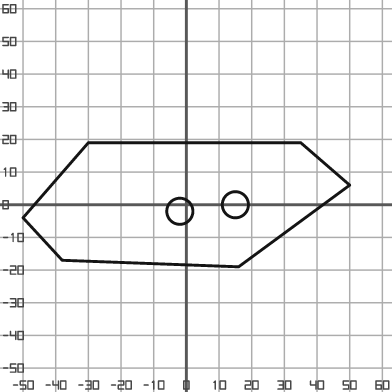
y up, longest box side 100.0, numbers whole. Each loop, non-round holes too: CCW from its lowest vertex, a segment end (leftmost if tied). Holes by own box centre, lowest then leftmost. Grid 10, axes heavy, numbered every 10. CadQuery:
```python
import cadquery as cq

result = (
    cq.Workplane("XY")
    .moveTo(16.0, -19.0)
    .lineTo(50.0, 6.0)
    .lineTo(35.0, 19.0)
    .lineTo(-30.0, 19.0)
    .lineTo(-50.0, -4.0)
    .lineTo(-38.0, -17.0)
    .close()
    .moveTo(-2.0, -2.0)
    .circle(4.0)
    .moveTo(15.0, 0.0)
    .circle(4.0)
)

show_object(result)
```